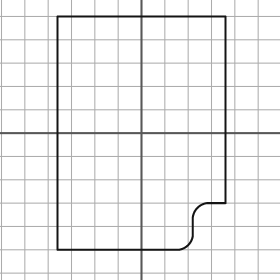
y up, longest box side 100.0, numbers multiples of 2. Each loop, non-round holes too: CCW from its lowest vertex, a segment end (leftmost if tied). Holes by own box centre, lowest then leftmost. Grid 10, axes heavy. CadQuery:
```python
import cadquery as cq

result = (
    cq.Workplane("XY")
    .moveTo(-36.0, -50.0)
    .lineTo(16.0, -50.0)
    .threePointArc((20.0, -48.0), (22.0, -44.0))
    .lineTo(22.0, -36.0)
    .threePointArc((24.0, -32.0), (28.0, -30.0))
    .lineTo(36.0, -30.0)
    .lineTo(36.0, 50.0)
    .lineTo(-36.0, 50.0)
    .close()
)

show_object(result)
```